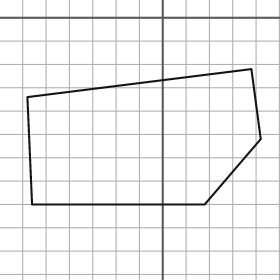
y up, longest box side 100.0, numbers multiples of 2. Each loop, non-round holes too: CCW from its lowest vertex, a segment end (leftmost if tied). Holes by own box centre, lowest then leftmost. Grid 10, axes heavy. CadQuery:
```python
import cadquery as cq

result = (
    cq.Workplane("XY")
    .moveTo(-56.0, -80.0)
    .lineTo(18.0, -80.0)
    .lineTo(42.0, -52.0)
    .lineTo(38.0, -22.0)
    .lineTo(-58.0, -34.0)
    .close()
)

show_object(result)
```